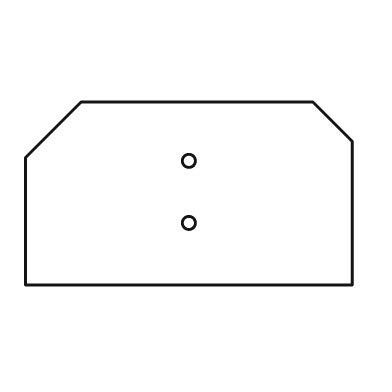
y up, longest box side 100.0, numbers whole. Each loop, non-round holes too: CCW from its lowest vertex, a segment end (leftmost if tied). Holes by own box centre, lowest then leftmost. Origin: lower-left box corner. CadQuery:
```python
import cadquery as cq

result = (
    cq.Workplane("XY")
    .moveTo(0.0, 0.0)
    .lineTo(100.0, 0.0)
    .lineTo(100.0, 44.0)
    .lineTo(88.0, 56.0)
    .lineTo(17.0, 56.0)
    .lineTo(0.0, 39.0)
    .close()
    .moveTo(50.0, 19.0)
    .circle(2.0)
    .moveTo(50.0, 38.0)
    .circle(2.0)
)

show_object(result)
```